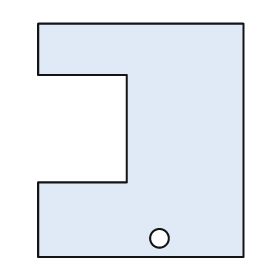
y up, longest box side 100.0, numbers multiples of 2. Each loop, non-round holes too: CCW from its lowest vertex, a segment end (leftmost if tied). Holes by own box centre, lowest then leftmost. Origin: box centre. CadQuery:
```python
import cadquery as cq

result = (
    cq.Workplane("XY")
    .moveTo(-44.0, -50.0)
    .lineTo(44.0, -50.0)
    .lineTo(44.0, 50.0)
    .lineTo(-44.0, 50.0)
    .lineTo(-44.0, 28.0)
    .lineTo(-6.0, 28.0)
    .lineTo(-6.0, -18.0)
    .lineTo(-44.0, -18.0)
    .close()
    .moveTo(8.0, -42.0)
    .circle(4.0)
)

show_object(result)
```